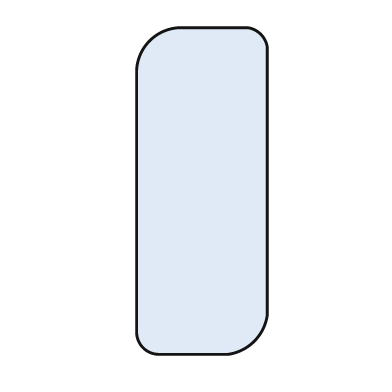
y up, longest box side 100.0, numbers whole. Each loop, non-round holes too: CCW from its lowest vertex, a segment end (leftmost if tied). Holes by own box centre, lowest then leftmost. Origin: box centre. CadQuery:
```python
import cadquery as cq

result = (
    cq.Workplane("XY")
    .moveTo(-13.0, -50.0)
    .lineTo(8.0, -50.0)
    .threePointArc((16.0, -46.0), (20.0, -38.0))
    .lineTo(20.0, 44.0)
    .threePointArc((18.0, 48.0), (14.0, 50.0))
    .lineTo(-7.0, 50.0)
    .threePointArc((-16.0, 46.0), (-20.0, 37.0))
    .lineTo(-20.0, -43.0)
    .threePointArc((-18.0, -48.0), (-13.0, -50.0))
    .close()
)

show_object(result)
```